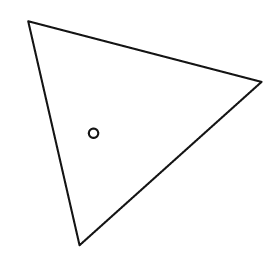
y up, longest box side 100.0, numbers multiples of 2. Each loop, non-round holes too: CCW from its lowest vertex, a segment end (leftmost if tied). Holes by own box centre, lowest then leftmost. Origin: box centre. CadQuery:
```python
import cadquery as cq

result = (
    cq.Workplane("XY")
    .moveTo(-28.0, -48.0)
    .lineTo(50.0, 22.0)
    .lineTo(-50.0, 48.0)
    .close()
    .moveTo(-22.0, 0.0)
    .circle(2.0)
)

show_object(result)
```